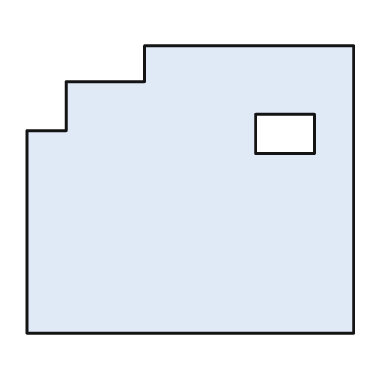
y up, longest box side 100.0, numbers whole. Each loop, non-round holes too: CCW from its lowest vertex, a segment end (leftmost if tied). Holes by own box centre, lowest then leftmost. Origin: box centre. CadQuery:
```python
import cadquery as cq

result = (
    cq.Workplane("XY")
    .moveTo(-50.0, -44.0)
    .lineTo(50.0, -44.0)
    .lineTo(50.0, 44.0)
    .lineTo(-14.0, 44.0)
    .lineTo(-14.0, 33.0)
    .lineTo(-38.0, 33.0)
    .lineTo(-38.0, 18.0)
    .lineTo(-50.0, 18.0)
    .close()
    .moveTo(20.0, 11.0)
    .lineTo(38.0, 11.0)
    .lineTo(38.0, 23.0)
    .lineTo(20.0, 23.0)
    .close()
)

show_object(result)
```